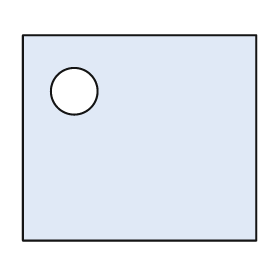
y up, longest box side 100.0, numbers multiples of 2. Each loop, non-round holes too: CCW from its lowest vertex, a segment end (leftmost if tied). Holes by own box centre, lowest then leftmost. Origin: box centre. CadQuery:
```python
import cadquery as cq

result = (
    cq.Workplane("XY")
    .moveTo(-50.0, -44.0)
    .lineTo(50.0, -44.0)
    .lineTo(50.0, 44.0)
    .lineTo(-50.0, 44.0)
    .close()
    .moveTo(-28.0, 20.0)
    .circle(10.0)
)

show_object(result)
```